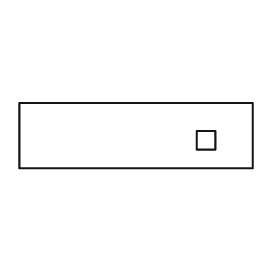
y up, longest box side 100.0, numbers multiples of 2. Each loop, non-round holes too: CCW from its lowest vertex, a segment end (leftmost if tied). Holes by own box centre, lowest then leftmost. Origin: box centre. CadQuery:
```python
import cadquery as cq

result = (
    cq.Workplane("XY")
    .moveTo(-50.0, -14.0)
    .lineTo(50.0, -14.0)
    .lineTo(50.0, 14.0)
    .lineTo(-50.0, 14.0)
    .close()
    .moveTo(26.0, -6.0)
    .lineTo(34.0, -6.0)
    .lineTo(34.0, 2.0)
    .lineTo(26.0, 2.0)
    .close()
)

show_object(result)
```